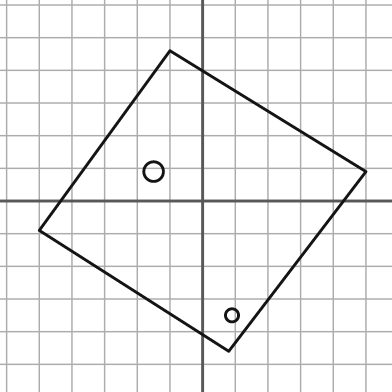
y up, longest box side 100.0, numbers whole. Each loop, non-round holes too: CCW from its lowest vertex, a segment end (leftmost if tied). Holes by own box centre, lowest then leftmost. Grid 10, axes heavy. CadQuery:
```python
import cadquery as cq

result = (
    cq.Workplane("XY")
    .moveTo(8.0, -46.0)
    .lineTo(50.0, 9.0)
    .lineTo(-10.0, 46.0)
    .lineTo(-50.0, -9.0)
    .close()
    .moveTo(9.0, -35.0)
    .circle(2.0)
    .moveTo(-15.0, 9.0)
    .circle(3.0)
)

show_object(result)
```